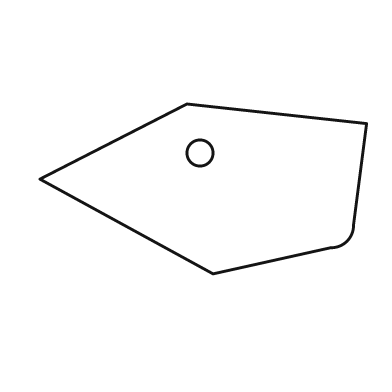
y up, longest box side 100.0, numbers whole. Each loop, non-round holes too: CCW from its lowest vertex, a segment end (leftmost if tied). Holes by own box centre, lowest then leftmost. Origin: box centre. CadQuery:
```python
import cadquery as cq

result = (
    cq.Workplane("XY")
    .moveTo(3.0, -26.0)
    .lineTo(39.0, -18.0)
    .threePointArc((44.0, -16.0), (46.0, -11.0))
    .lineTo(50.0, 20.0)
    .lineTo(-5.0, 26.0)
    .lineTo(-50.0, 3.0)
    .close()
    .moveTo(-1.0, 11.0)
    .circle(4.0)
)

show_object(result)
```